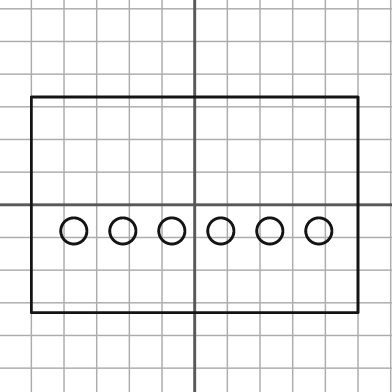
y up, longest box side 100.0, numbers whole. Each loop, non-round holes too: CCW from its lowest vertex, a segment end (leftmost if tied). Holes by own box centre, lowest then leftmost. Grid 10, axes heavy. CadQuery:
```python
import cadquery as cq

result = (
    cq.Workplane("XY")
    .moveTo(-50.0, -33.0)
    .lineTo(50.0, -33.0)
    .lineTo(50.0, 33.0)
    .lineTo(-50.0, 33.0)
    .close()
    .moveTo(-37.0, -8.0)
    .circle(4.0)
    .moveTo(-22.0, -8.0)
    .circle(4.0)
    .moveTo(-7.0, -8.0)
    .circle(4.0)
    .moveTo(8.0, -8.0)
    .circle(4.0)
    .moveTo(23.0, -8.0)
    .circle(4.0)
    .moveTo(38.0, -8.0)
    .circle(4.0)
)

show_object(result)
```